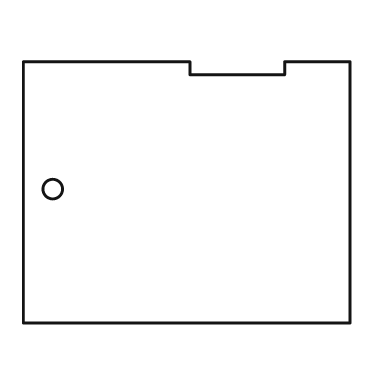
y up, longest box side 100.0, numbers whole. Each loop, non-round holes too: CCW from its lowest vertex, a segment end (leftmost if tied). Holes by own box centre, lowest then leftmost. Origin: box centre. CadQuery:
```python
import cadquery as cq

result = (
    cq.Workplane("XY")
    .moveTo(-50.0, -40.0)
    .lineTo(50.0, -40.0)
    .lineTo(50.0, 40.0)
    .lineTo(30.0, 40.0)
    .lineTo(30.0, 36.0)
    .lineTo(1.0, 36.0)
    .lineTo(1.0, 40.0)
    .lineTo(-50.0, 40.0)
    .close()
    .moveTo(-41.0, 1.0)
    .circle(3.0)
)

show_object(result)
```